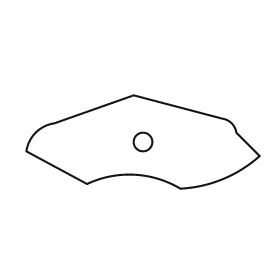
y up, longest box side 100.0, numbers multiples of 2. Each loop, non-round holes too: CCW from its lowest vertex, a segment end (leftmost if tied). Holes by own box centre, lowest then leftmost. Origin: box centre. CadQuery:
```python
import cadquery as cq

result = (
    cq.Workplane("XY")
    .moveTo(16.0, -20.0)
    .threePointArc((34.0, -16.0), (50.0, -6.0))
    .lineTo(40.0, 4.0)
    .threePointArc((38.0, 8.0), (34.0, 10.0))
    .lineTo(-4.0, 20.0)
    .lineTo(-38.0, 8.0)
    .threePointArc((-46.0, 4.0), (-50.0, -4.0))
    .lineTo(-24.0, -18.0)
    .threePointArc((-4.0, -14.0), (16.0, -20.0))
    .close()
    .moveTo(0.0, 0.0)
    .circle(4.0)
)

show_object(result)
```